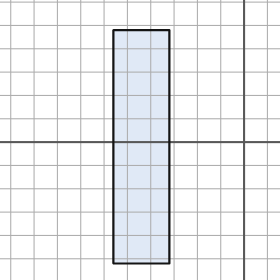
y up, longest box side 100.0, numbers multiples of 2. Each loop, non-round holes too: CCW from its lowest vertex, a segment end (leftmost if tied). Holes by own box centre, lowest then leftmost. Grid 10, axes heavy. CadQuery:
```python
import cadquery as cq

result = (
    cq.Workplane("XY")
    .moveTo(-56.0, -52.0)
    .lineTo(-32.0, -52.0)
    .lineTo(-32.0, 48.0)
    .lineTo(-56.0, 48.0)
    .close()
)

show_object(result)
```